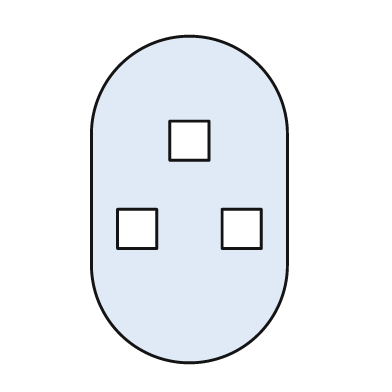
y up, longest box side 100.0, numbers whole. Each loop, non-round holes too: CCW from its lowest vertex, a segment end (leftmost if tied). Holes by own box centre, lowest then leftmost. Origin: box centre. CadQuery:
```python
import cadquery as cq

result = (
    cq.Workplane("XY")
    .moveTo(-30.0, -20.0)
    .threePointArc((0.0, -50.0), (30.0, -20.0))
    .lineTo(30.0, 20.0)
    .threePointArc((0.0, 50.0), (-30.0, 20.0))
    .close()
    .moveTo(-22.0, -15.0)
    .lineTo(-10.0, -15.0)
    .lineTo(-10.0, -3.0)
    .lineTo(-22.0, -3.0)
    .close()
    .moveTo(10.0, -15.0)
    .lineTo(22.0, -15.0)
    .lineTo(22.0, -3.0)
    .lineTo(10.0, -3.0)
    .close()
    .moveTo(-6.0, 12.0)
    .lineTo(6.0, 12.0)
    .lineTo(6.0, 24.0)
    .lineTo(-6.0, 24.0)
    .close()
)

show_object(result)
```